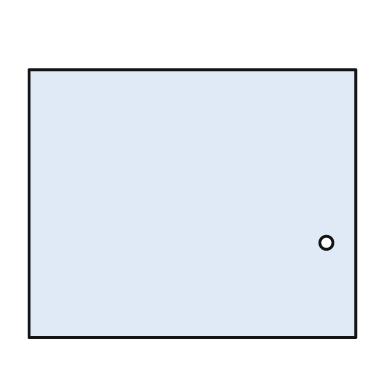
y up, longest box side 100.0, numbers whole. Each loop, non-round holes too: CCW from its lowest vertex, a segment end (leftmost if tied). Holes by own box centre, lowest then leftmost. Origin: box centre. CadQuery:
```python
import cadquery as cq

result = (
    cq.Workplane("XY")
    .moveTo(-50.0, -41.0)
    .lineTo(50.0, -41.0)
    .lineTo(50.0, 41.0)
    .lineTo(-50.0, 41.0)
    .close()
    .moveTo(41.0, -12.0)
    .circle(2.0)
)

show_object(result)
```